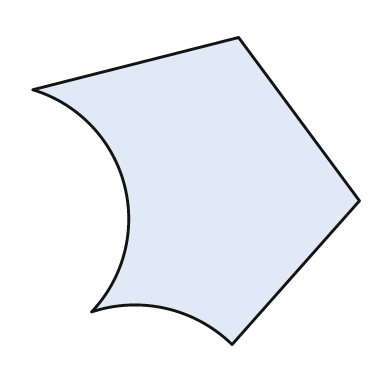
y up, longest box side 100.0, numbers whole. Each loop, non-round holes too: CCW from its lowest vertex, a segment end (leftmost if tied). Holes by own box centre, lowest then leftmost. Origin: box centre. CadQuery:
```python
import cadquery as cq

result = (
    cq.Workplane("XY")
    .moveTo(11.0, -47.0)
    .lineTo(50.0, -3.0)
    .lineTo(13.0, 47.0)
    .lineTo(-50.0, 31.0)
    .threePointArc((-22.0, 2.0), (-32.0, -37.0))
    .threePointArc((-9.0, -36.0), (11.0, -47.0))
    .close()
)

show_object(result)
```